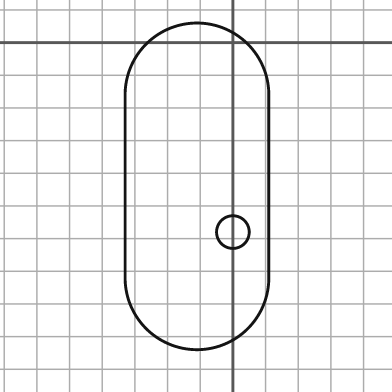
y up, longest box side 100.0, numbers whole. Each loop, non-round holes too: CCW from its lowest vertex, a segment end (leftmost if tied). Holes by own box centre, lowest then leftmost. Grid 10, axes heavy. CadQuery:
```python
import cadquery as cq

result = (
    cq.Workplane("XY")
    .moveTo(-33.0, -72.0)
    .threePointArc((-11.0, -94.0), (11.0, -72.0))
    .lineTo(11.0, -16.0)
    .threePointArc((-11.0, 6.0), (-33.0, -16.0))
    .close()
    .moveTo(0.0, -58.0)
    .circle(5.0)
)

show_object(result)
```